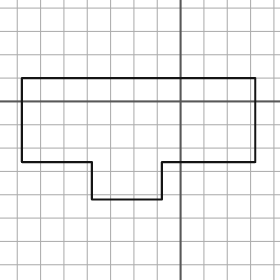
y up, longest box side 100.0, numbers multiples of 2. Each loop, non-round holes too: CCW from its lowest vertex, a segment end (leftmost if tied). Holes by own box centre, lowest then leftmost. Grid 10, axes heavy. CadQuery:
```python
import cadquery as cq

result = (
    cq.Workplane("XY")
    .moveTo(-38.0, -42.0)
    .lineTo(-8.0, -42.0)
    .lineTo(-8.0, -26.0)
    .lineTo(32.0, -26.0)
    .lineTo(32.0, 10.0)
    .lineTo(-68.0, 10.0)
    .lineTo(-68.0, -26.0)
    .lineTo(-38.0, -26.0)
    .close()
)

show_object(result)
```